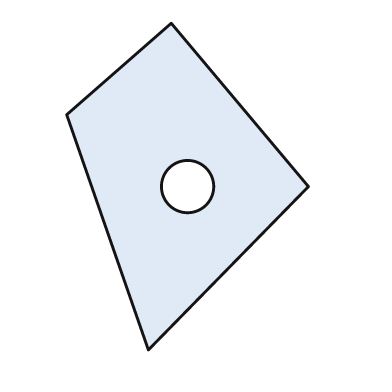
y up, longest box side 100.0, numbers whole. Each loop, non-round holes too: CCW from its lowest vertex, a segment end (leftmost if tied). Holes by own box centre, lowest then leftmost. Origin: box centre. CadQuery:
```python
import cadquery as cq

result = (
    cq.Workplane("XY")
    .moveTo(-12.0, -50.0)
    .lineTo(37.0, 0.0)
    .lineTo(-5.0, 50.0)
    .lineTo(-37.0, 22.0)
    .close()
    .moveTo(0.0, 0.0)
    .circle(8.0)
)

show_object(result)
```